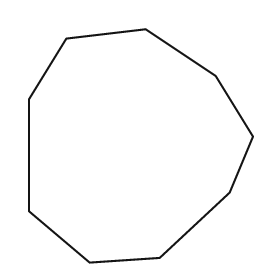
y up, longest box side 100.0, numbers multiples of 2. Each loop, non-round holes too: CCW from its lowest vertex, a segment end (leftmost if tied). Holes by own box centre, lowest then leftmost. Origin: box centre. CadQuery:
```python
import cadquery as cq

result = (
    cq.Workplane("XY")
    .moveTo(-22.0, -50.0)
    .lineTo(8.0, -48.0)
    .lineTo(38.0, -20.0)
    .lineTo(48.0, 4.0)
    .lineTo(32.0, 30.0)
    .lineTo(2.0, 50.0)
    .lineTo(-32.0, 46.0)
    .lineTo(-48.0, 20.0)
    .lineTo(-48.0, -28.0)
    .close()
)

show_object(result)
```